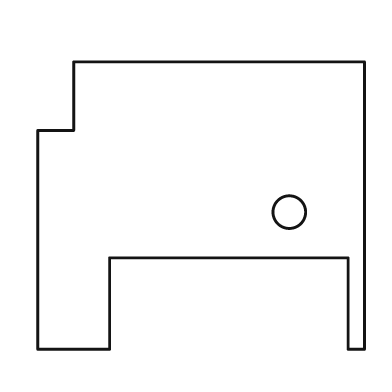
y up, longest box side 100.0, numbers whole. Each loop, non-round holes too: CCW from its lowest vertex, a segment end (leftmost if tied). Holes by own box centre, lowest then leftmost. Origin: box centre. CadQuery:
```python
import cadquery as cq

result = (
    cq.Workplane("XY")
    .moveTo(-50.0, -44.0)
    .lineTo(-28.0, -44.0)
    .lineTo(-28.0, -16.0)
    .lineTo(45.0, -16.0)
    .lineTo(45.0, -44.0)
    .lineTo(50.0, -44.0)
    .lineTo(50.0, 44.0)
    .lineTo(-39.0, 44.0)
    .lineTo(-39.0, 23.0)
    .lineTo(-50.0, 23.0)
    .close()
    .moveTo(27.0, -2.0)
    .circle(5.0)
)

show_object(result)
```